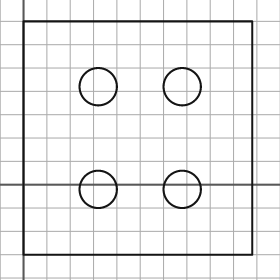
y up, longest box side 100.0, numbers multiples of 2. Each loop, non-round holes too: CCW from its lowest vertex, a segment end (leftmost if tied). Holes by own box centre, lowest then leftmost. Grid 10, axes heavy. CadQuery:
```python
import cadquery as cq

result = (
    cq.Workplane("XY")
    .moveTo(0.0, -30.0)
    .lineTo(98.0, -30.0)
    .lineTo(98.0, 70.0)
    .lineTo(0.0, 70.0)
    .close()
    .moveTo(32.0, -2.0)
    .circle(8.0)
    .moveTo(68.0, -2.0)
    .circle(8.0)
    .moveTo(32.0, 42.0)
    .circle(8.0)
    .moveTo(68.0, 42.0)
    .circle(8.0)
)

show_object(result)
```